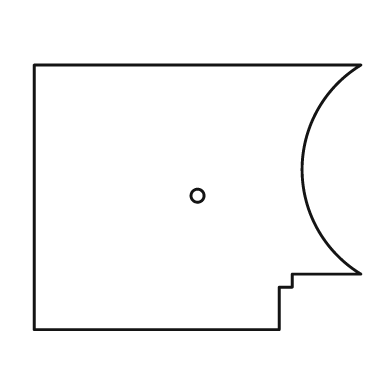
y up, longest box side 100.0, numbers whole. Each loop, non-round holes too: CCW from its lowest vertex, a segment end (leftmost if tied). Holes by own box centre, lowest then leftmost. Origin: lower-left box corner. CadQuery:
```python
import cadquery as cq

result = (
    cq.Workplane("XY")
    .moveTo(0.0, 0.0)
    .lineTo(75.0, 0.0)
    .lineTo(75.0, 13.0)
    .lineTo(79.0, 13.0)
    .lineTo(79.0, 17.0)
    .lineTo(100.0, 17.0)
    .threePointArc((82.0, 49.0), (100.0, 81.0))
    .lineTo(0.0, 81.0)
    .close()
    .moveTo(50.0, 41.0)
    .circle(2.0)
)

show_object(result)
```